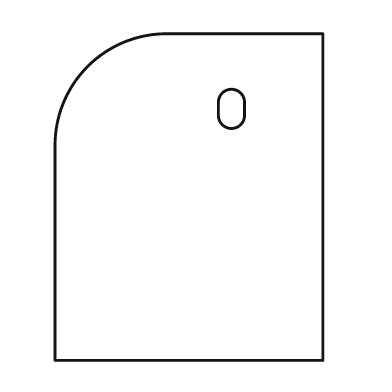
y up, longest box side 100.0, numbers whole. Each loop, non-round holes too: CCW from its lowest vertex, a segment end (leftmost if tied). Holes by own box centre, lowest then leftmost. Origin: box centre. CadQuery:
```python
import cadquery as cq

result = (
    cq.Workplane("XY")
    .moveTo(-41.0, -50.0)
    .lineTo(41.0, -50.0)
    .lineTo(41.0, 50.0)
    .lineTo(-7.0, 50.0)
    .threePointArc((-31.0, 40.0), (-41.0, 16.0))
    .close()
    .moveTo(9.0, 25.0)
    .threePointArc((13.0, 21.0), (17.0, 25.0))
    .lineTo(17.0, 29.0)
    .threePointArc((13.0, 33.0), (9.0, 29.0))
    .close()
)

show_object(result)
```